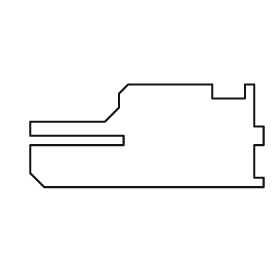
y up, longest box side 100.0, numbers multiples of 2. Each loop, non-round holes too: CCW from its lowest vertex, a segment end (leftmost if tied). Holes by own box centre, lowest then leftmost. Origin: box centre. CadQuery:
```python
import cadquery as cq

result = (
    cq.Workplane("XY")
    .moveTo(-44.0, -22.0)
    .lineTo(50.0, -22.0)
    .lineTo(50.0, -18.0)
    .lineTo(46.0, -18.0)
    .lineTo(46.0, -4.0)
    .lineTo(50.0, -4.0)
    .lineTo(50.0, 4.0)
    .lineTo(46.0, 4.0)
    .lineTo(46.0, 22.0)
    .lineTo(42.0, 22.0)
    .lineTo(42.0, 16.0)
    .lineTo(28.0, 16.0)
    .lineTo(28.0, 22.0)
    .lineTo(-8.0, 22.0)
    .lineTo(-12.0, 18.0)
    .lineTo(-12.0, 12.0)
    .lineTo(-18.0, 6.0)
    .lineTo(-50.0, 6.0)
    .lineTo(-50.0, 0.0)
    .lineTo(-10.0, 0.0)
    .lineTo(-10.0, -4.0)
    .lineTo(-50.0, -4.0)
    .lineTo(-50.0, -16.0)
    .close()
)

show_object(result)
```